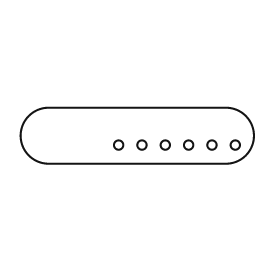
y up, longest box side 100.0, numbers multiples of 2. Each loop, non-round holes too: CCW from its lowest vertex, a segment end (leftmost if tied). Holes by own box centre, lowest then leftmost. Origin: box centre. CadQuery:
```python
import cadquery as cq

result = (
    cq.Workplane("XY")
    .moveTo(-38.0, -12.0)
    .lineTo(38.0, -12.0)
    .threePointArc((50.0, 0.0), (38.0, 12.0))
    .lineTo(-38.0, 12.0)
    .threePointArc((-50.0, 0.0), (-38.0, -12.0))
    .close()
    .moveTo(-8.0, -4.0)
    .circle(2.0)
    .moveTo(2.0, -4.0)
    .circle(2.0)
    .moveTo(12.0, -4.0)
    .circle(2.0)
    .moveTo(22.0, -4.0)
    .circle(2.0)
    .moveTo(32.0, -4.0)
    .circle(2.0)
    .moveTo(42.0, -4.0)
    .circle(2.0)
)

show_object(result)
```